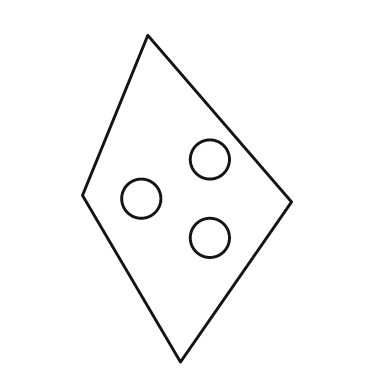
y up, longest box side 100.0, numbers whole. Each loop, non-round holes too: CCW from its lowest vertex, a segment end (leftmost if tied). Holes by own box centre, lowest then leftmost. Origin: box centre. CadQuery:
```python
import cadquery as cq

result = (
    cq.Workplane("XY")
    .moveTo(-2.0, -50.0)
    .lineTo(32.0, -1.0)
    .lineTo(-12.0, 50.0)
    .lineTo(-32.0, 1.0)
    .close()
    .moveTo(7.0, -12.0)
    .circle(6.0)
    .moveTo(-14.0, 0.0)
    .circle(6.0)
    .moveTo(7.0, 12.0)
    .circle(6.0)
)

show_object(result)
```